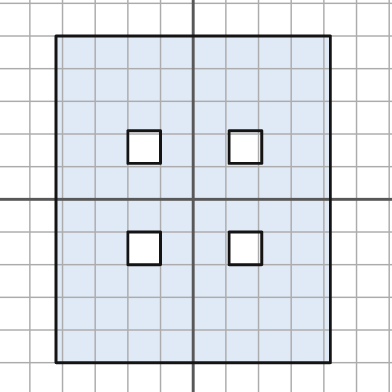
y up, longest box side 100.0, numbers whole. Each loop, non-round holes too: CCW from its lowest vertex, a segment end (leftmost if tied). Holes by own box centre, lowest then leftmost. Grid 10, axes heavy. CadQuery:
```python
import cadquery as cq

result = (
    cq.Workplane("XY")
    .moveTo(-42.0, -50.0)
    .lineTo(42.0, -50.0)
    .lineTo(42.0, 50.0)
    .lineTo(-42.0, 50.0)
    .close()
    .moveTo(-20.0, -20.0)
    .lineTo(-10.0, -20.0)
    .lineTo(-10.0, -10.0)
    .lineTo(-20.0, -10.0)
    .close()
    .moveTo(11.0, -20.0)
    .lineTo(21.0, -20.0)
    .lineTo(21.0, -10.0)
    .lineTo(11.0, -10.0)
    .close()
    .moveTo(-20.0, 11.0)
    .lineTo(-10.0, 11.0)
    .lineTo(-10.0, 21.0)
    .lineTo(-20.0, 21.0)
    .close()
    .moveTo(11.0, 11.0)
    .lineTo(21.0, 11.0)
    .lineTo(21.0, 21.0)
    .lineTo(11.0, 21.0)
    .close()
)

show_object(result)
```